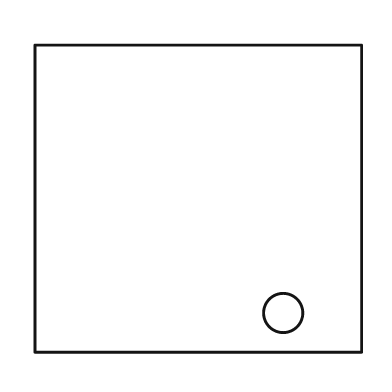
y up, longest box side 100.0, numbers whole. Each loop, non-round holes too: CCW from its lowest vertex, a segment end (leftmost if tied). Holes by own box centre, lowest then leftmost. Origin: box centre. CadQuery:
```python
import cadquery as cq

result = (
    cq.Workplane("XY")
    .moveTo(-50.0, -47.0)
    .lineTo(50.0, -47.0)
    .lineTo(50.0, 47.0)
    .lineTo(-50.0, 47.0)
    .close()
    .moveTo(26.0, -35.0)
    .circle(6.0)
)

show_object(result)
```